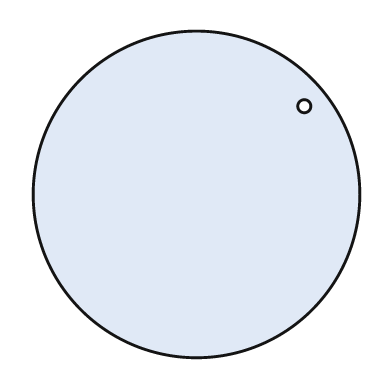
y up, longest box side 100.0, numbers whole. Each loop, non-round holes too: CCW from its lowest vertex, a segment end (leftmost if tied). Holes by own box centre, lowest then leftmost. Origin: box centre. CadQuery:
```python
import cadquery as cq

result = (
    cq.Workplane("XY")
    .moveTo(0.0, 0.0)
    .circle(50.0)
    .moveTo(33.0, 27.0)
    .circle(2.0)
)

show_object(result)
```